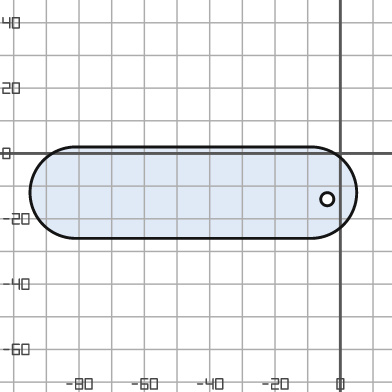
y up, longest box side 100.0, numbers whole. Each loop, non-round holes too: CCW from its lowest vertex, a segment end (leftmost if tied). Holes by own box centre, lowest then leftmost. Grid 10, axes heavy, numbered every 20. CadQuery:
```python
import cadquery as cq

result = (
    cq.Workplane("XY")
    .moveTo(-81.0, -26.0)
    .lineTo(-9.0, -26.0)
    .threePointArc((5.0, -12.0), (-9.0, 2.0))
    .lineTo(-81.0, 2.0)
    .threePointArc((-95.0, -12.0), (-81.0, -26.0))
    .close()
    .moveTo(-4.0, -14.0)
    .circle(2.0)
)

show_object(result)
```